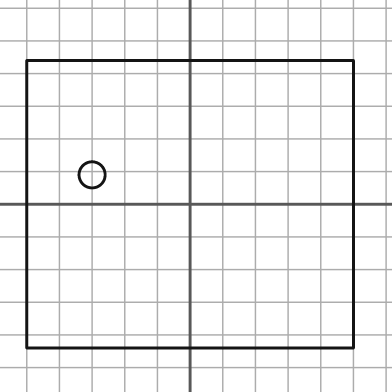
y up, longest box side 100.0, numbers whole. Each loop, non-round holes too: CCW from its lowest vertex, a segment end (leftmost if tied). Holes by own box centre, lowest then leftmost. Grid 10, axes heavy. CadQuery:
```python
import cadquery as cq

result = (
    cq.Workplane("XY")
    .moveTo(-50.0, -44.0)
    .lineTo(50.0, -44.0)
    .lineTo(50.0, 44.0)
    .lineTo(-50.0, 44.0)
    .close()
    .moveTo(-30.0, 9.0)
    .circle(4.0)
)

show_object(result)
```